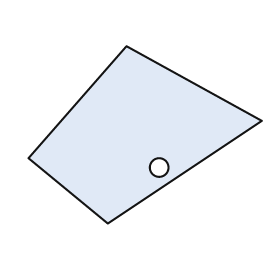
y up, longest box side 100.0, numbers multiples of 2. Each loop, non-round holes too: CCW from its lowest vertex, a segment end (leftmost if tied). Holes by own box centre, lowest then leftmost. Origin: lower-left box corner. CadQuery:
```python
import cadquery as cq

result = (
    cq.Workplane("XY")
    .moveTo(34.0, 0.0)
    .lineTo(100.0, 44.0)
    .lineTo(42.0, 76.0)
    .lineTo(0.0, 28.0)
    .close()
    .moveTo(56.0, 24.0)
    .circle(4.0)
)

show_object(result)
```